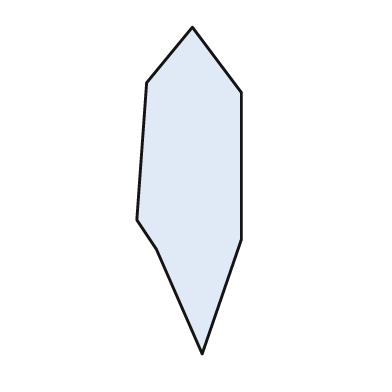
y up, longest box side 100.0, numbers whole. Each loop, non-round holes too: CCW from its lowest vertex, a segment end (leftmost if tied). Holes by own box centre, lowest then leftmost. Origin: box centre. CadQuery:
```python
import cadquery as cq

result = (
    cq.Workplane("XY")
    .moveTo(4.0, -50.0)
    .lineTo(16.0, -15.0)
    .lineTo(16.0, 30.0)
    .lineTo(1.0, 50.0)
    .lineTo(-13.0, 33.0)
    .lineTo(-16.0, -9.0)
    .lineTo(-10.0, -18.0)
    .close()
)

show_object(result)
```